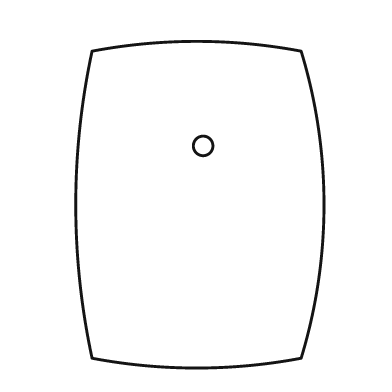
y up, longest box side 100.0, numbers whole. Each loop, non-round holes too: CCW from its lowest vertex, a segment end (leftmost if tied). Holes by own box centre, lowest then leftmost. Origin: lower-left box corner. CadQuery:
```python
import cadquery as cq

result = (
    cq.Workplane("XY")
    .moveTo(5.0, 3.0)
    .threePointArc((37.0, 0.0), (69.0, 3.0))
    .threePointArc((76.0, 50.0), (69.0, 97.0))
    .threePointArc((37.0, 100.0), (5.0, 97.0))
    .threePointArc((0.0, 50.0), (5.0, 3.0))
    .close()
    .moveTo(39.0, 68.0)
    .circle(3.0)
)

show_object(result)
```